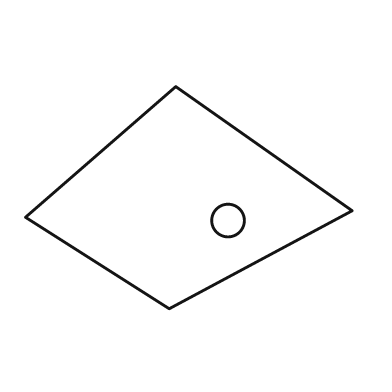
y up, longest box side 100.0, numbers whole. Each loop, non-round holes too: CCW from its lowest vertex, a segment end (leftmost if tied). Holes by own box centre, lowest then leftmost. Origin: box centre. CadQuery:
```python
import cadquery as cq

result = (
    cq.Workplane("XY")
    .moveTo(-6.0, -34.0)
    .lineTo(50.0, -4.0)
    .lineTo(-4.0, 34.0)
    .lineTo(-50.0, -6.0)
    .close()
    .moveTo(12.0, -7.0)
    .circle(5.0)
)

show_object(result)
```